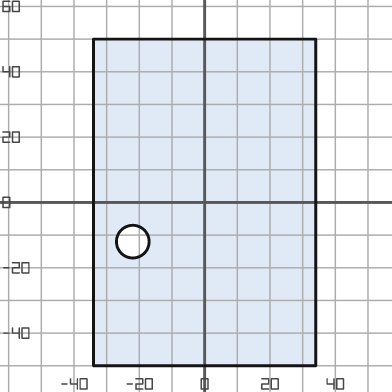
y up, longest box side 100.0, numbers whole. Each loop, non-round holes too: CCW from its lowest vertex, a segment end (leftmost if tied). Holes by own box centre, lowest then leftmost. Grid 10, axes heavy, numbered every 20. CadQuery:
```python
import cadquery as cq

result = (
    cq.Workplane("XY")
    .moveTo(-34.0, -50.0)
    .lineTo(34.0, -50.0)
    .lineTo(34.0, 50.0)
    .lineTo(-34.0, 50.0)
    .close()
    .moveTo(-22.0, -12.0)
    .circle(5.0)
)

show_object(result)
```